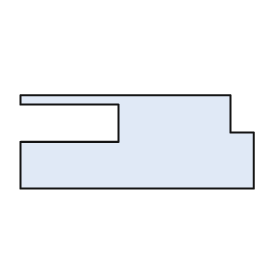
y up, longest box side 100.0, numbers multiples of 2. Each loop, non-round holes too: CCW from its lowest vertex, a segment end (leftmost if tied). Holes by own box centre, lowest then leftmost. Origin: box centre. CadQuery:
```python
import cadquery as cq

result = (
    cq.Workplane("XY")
    .moveTo(-50.0, -20.0)
    .lineTo(50.0, -20.0)
    .lineTo(50.0, 4.0)
    .lineTo(40.0, 4.0)
    .lineTo(40.0, 20.0)
    .lineTo(-50.0, 20.0)
    .lineTo(-50.0, 16.0)
    .lineTo(-8.0, 16.0)
    .lineTo(-8.0, 0.0)
    .lineTo(-50.0, 0.0)
    .close()
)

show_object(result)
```